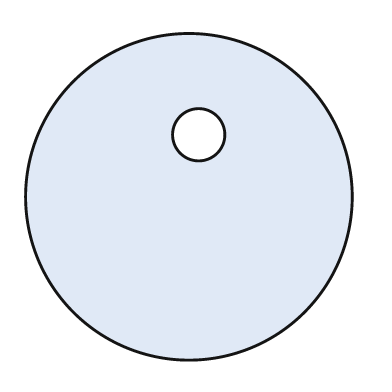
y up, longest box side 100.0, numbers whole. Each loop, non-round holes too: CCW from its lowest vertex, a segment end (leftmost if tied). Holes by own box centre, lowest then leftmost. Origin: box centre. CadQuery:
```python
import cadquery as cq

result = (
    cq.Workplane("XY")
    .moveTo(0.0, 0.0)
    .circle(50.0)
    .moveTo(3.0, 19.0)
    .circle(8.0)
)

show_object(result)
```